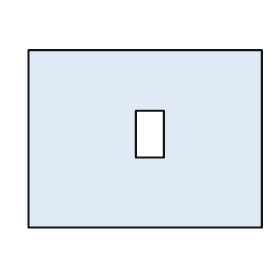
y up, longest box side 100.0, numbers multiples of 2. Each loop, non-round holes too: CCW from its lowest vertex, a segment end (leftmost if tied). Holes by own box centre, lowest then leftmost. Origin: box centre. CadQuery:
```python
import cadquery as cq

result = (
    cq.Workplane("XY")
    .moveTo(-50.0, -38.0)
    .lineTo(50.0, -38.0)
    .lineTo(50.0, 38.0)
    .lineTo(-50.0, 38.0)
    .close()
    .moveTo(-4.0, -8.0)
    .lineTo(8.0, -8.0)
    .lineTo(8.0, 12.0)
    .lineTo(-4.0, 12.0)
    .close()
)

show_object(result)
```